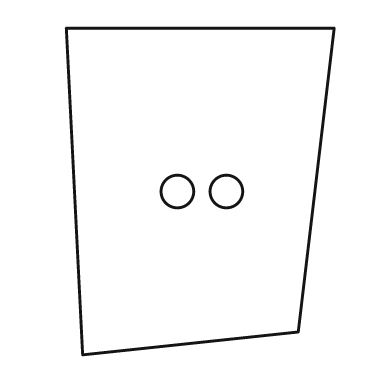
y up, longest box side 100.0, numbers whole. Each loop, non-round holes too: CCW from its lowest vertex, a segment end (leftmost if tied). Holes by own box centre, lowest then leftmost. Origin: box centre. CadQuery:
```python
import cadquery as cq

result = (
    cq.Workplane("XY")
    .moveTo(-36.0, -50.0)
    .lineTo(30.0, -43.0)
    .lineTo(41.0, 50.0)
    .lineTo(-41.0, 50.0)
    .close()
    .moveTo(-7.0, 0.0)
    .circle(5.0)
    .moveTo(8.0, 0.0)
    .circle(5.0)
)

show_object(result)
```